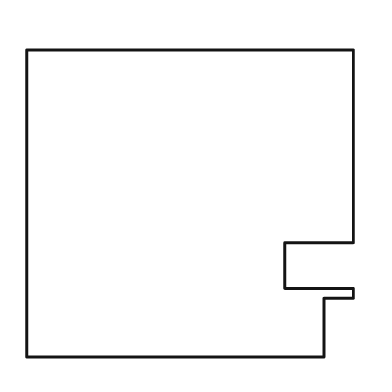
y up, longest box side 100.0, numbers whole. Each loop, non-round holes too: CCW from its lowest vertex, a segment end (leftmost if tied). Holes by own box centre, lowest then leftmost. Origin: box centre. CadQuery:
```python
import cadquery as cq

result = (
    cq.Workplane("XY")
    .moveTo(-50.0, -47.0)
    .lineTo(41.0, -47.0)
    .lineTo(41.0, -29.0)
    .lineTo(50.0, -29.0)
    .lineTo(50.0, -26.0)
    .lineTo(29.0, -26.0)
    .lineTo(29.0, -12.0)
    .lineTo(50.0, -12.0)
    .lineTo(50.0, 47.0)
    .lineTo(-50.0, 47.0)
    .close()
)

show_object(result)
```